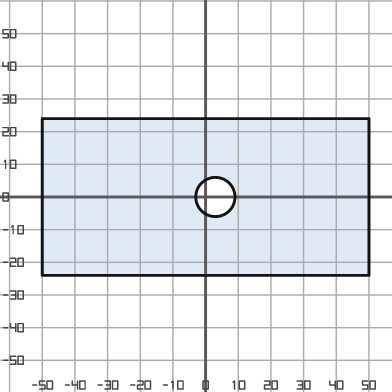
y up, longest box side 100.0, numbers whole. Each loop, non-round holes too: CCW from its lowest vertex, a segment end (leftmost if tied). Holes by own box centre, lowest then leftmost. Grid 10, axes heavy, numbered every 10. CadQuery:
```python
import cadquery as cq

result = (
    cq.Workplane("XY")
    .moveTo(-50.0, -24.0)
    .lineTo(50.0, -24.0)
    .lineTo(50.0, 24.0)
    .lineTo(-50.0, 24.0)
    .close()
    .moveTo(3.0, 0.0)
    .circle(6.0)
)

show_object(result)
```